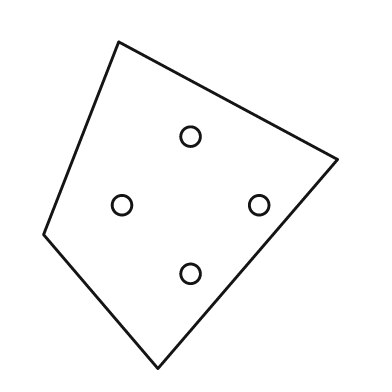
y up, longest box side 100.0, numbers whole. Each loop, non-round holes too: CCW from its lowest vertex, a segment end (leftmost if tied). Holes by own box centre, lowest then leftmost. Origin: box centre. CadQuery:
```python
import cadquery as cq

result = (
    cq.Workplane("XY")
    .moveTo(-10.0, -50.0)
    .lineTo(45.0, 14.0)
    .lineTo(-22.0, 50.0)
    .lineTo(-45.0, -9.0)
    .close()
    .moveTo(0.0, -21.0)
    .circle(3.0)
    .moveTo(-21.0, 0.0)
    .circle(3.0)
    .moveTo(21.0, 0.0)
    .circle(3.0)
    .moveTo(0.0, 21.0)
    .circle(3.0)
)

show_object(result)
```